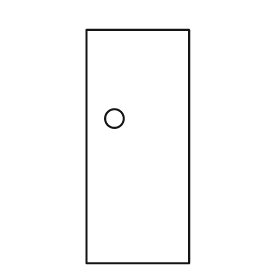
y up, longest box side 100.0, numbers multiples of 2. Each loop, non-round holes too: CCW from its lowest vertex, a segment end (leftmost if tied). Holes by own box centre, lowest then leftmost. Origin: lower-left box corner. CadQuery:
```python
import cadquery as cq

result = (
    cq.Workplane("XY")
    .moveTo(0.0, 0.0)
    .lineTo(44.0, 0.0)
    .lineTo(44.0, 100.0)
    .lineTo(0.0, 100.0)
    .close()
    .moveTo(12.0, 62.0)
    .circle(4.0)
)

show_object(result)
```